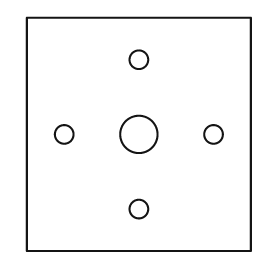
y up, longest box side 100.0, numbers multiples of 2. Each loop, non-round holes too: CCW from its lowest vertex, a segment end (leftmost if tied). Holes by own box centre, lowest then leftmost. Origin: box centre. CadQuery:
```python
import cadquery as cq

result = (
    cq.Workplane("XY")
    .moveTo(-48.0, -50.0)
    .lineTo(48.0, -50.0)
    .lineTo(48.0, 50.0)
    .lineTo(-48.0, 50.0)
    .close()
    .moveTo(0.0, -32.0)
    .circle(4.0)
    .moveTo(-32.0, 0.0)
    .circle(4.0)
    .moveTo(0.0, 0.0)
    .circle(8.0)
    .moveTo(32.0, 0.0)
    .circle(4.0)
    .moveTo(0.0, 32.0)
    .circle(4.0)
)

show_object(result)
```